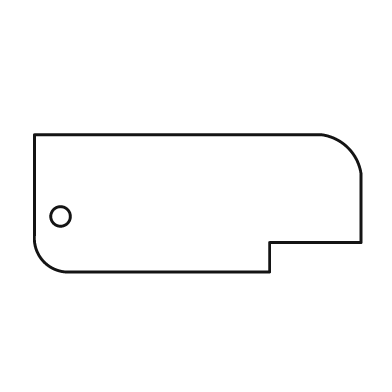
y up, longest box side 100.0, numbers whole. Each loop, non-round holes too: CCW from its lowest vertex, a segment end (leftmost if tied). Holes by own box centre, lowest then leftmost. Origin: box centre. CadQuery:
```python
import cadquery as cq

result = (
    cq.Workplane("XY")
    .moveTo(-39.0, -21.0)
    .lineTo(22.0, -21.0)
    .lineTo(22.0, -12.0)
    .lineTo(50.0, -12.0)
    .lineTo(50.0, 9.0)
    .threePointArc((46.0, 17.0), (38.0, 21.0))
    .lineTo(-50.0, 21.0)
    .lineTo(-50.0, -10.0)
    .threePointArc((-47.0, -18.0), (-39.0, -21.0))
    .close()
    .moveTo(-42.0, -4.0)
    .circle(3.0)
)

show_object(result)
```